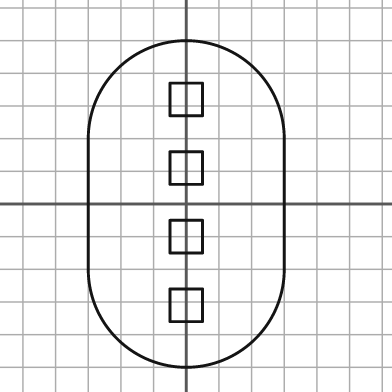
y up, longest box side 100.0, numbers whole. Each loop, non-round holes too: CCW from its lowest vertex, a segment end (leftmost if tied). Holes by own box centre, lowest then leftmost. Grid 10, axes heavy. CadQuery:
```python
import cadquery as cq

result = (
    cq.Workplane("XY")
    .moveTo(-30.0, -20.0)
    .threePointArc((0.0, -50.0), (30.0, -20.0))
    .lineTo(30.0, 20.0)
    .threePointArc((0.0, 50.0), (-30.0, 20.0))
    .close()
    .moveTo(-5.0, -36.0)
    .lineTo(5.0, -36.0)
    .lineTo(5.0, -26.0)
    .lineTo(-5.0, -26.0)
    .close()
    .moveTo(-5.0, -15.0)
    .lineTo(5.0, -15.0)
    .lineTo(5.0, -5.0)
    .lineTo(-5.0, -5.0)
    .close()
    .moveTo(-5.0, 6.0)
    .lineTo(5.0, 6.0)
    .lineTo(5.0, 16.0)
    .lineTo(-5.0, 16.0)
    .close()
    .moveTo(-5.0, 27.0)
    .lineTo(5.0, 27.0)
    .lineTo(5.0, 37.0)
    .lineTo(-5.0, 37.0)
    .close()
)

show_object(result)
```